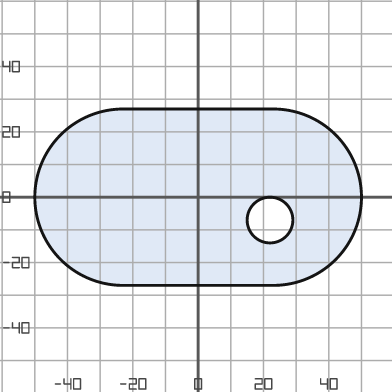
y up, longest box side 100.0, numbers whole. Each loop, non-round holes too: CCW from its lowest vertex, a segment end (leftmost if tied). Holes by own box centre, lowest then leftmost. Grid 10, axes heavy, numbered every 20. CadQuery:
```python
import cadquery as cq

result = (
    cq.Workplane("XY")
    .moveTo(-23.0, -27.0)
    .lineTo(23.0, -27.0)
    .threePointArc((50.0, 0.0), (23.0, 27.0))
    .lineTo(-23.0, 27.0)
    .threePointArc((-50.0, 0.0), (-23.0, -27.0))
    .close()
    .moveTo(22.0, -7.0)
    .circle(7.0)
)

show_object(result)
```